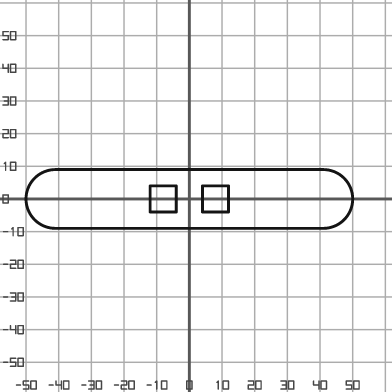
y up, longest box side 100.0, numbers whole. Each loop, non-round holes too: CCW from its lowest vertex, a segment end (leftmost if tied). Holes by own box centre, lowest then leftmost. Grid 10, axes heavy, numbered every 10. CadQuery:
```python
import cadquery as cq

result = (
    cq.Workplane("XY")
    .moveTo(-41.0, -9.0)
    .lineTo(41.0, -9.0)
    .threePointArc((50.0, 0.0), (41.0, 9.0))
    .lineTo(-41.0, 9.0)
    .threePointArc((-50.0, 0.0), (-41.0, -9.0))
    .close()
    .moveTo(-12.0, -4.0)
    .lineTo(-4.0, -4.0)
    .lineTo(-4.0, 4.0)
    .lineTo(-12.0, 4.0)
    .close()
    .moveTo(4.0, -4.0)
    .lineTo(12.0, -4.0)
    .lineTo(12.0, 4.0)
    .lineTo(4.0, 4.0)
    .close()
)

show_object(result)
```